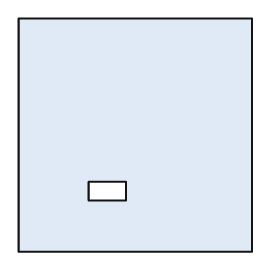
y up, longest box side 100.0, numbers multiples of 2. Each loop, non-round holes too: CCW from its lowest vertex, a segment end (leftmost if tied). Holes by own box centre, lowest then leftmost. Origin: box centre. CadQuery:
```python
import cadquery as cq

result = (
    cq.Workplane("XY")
    .moveTo(-50.0, -50.0)
    .lineTo(50.0, -50.0)
    .lineTo(50.0, 50.0)
    .lineTo(-50.0, 50.0)
    .close()
    .moveTo(-20.0, -28.0)
    .lineTo(-4.0, -28.0)
    .lineTo(-4.0, -20.0)
    .lineTo(-20.0, -20.0)
    .close()
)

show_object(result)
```